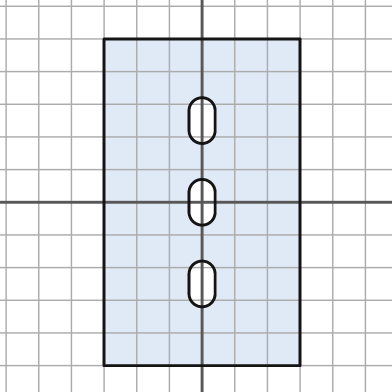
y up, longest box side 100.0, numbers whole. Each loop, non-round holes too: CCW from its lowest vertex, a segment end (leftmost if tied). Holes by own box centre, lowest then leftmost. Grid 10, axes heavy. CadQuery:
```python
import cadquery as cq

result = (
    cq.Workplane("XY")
    .moveTo(-30.0, -50.0)
    .lineTo(30.0, -50.0)
    .lineTo(30.0, 50.0)
    .lineTo(-30.0, 50.0)
    .close()
    .moveTo(-4.0, -28.0)
    .threePointArc((0.0, -32.0), (4.0, -28.0))
    .lineTo(4.0, -22.0)
    .threePointArc((0.0, -18.0), (-4.0, -22.0))
    .close()
    .moveTo(-4.0, -3.0)
    .threePointArc((0.0, -7.0), (4.0, -3.0))
    .lineTo(4.0, 3.0)
    .threePointArc((0.0, 7.0), (-4.0, 3.0))
    .close()
    .moveTo(-4.0, 22.0)
    .threePointArc((0.0, 18.0), (4.0, 22.0))
    .lineTo(4.0, 28.0)
    .threePointArc((0.0, 32.0), (-4.0, 28.0))
    .close()
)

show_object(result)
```